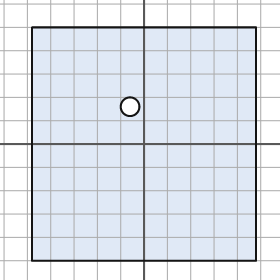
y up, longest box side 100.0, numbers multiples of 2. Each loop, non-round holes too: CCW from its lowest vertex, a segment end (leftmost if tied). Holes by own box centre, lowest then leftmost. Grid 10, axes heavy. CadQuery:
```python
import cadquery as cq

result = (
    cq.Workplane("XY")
    .moveTo(-48.0, -50.0)
    .lineTo(48.0, -50.0)
    .lineTo(48.0, 50.0)
    .lineTo(-48.0, 50.0)
    .close()
    .moveTo(-6.0, 16.0)
    .circle(4.0)
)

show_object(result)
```